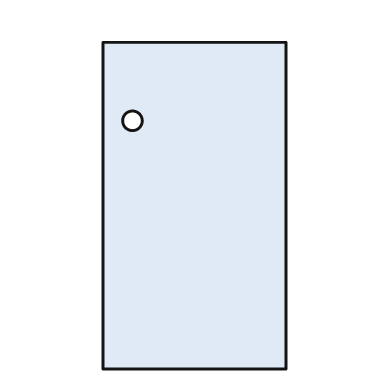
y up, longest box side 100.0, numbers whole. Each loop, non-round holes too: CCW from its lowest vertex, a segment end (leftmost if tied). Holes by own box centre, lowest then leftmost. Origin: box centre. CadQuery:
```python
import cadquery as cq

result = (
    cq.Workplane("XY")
    .moveTo(-28.0, -50.0)
    .lineTo(28.0, -50.0)
    .lineTo(28.0, 50.0)
    .lineTo(-28.0, 50.0)
    .close()
    .moveTo(-19.0, 26.0)
    .circle(3.0)
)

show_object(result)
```